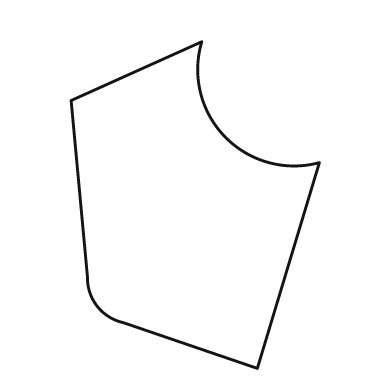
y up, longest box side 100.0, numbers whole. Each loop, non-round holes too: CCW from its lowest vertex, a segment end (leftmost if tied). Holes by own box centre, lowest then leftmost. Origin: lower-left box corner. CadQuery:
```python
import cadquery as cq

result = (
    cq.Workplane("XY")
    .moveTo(57.0, 0.0)
    .lineTo(76.0, 63.0)
    .threePointArc((47.0, 71.0), (40.0, 100.0))
    .lineTo(0.0, 82.0)
    .lineTo(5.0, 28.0)
    .threePointArc((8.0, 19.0), (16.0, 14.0))
    .close()
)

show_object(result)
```